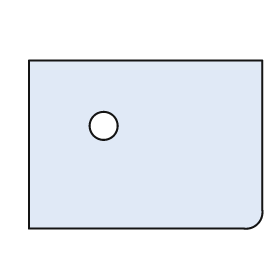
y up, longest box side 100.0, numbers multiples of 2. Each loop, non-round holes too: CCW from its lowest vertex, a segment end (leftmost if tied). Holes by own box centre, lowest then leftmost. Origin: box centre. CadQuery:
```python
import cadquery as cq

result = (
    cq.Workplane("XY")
    .moveTo(-50.0, -36.0)
    .lineTo(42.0, -36.0)
    .threePointArc((48.0, -34.0), (50.0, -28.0))
    .lineTo(50.0, 36.0)
    .lineTo(-50.0, 36.0)
    .close()
    .moveTo(-18.0, 8.0)
    .circle(6.0)
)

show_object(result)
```